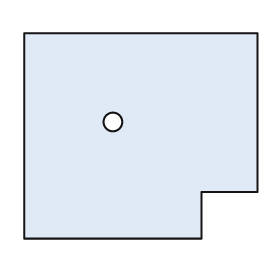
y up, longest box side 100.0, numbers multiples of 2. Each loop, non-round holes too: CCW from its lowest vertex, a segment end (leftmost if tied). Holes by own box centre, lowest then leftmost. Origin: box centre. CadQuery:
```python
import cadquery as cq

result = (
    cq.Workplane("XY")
    .moveTo(-50.0, -44.0)
    .lineTo(26.0, -44.0)
    .lineTo(26.0, -24.0)
    .lineTo(50.0, -24.0)
    .lineTo(50.0, 44.0)
    .lineTo(-50.0, 44.0)
    .close()
    .moveTo(-12.0, 6.0)
    .circle(4.0)
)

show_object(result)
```